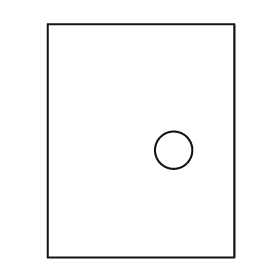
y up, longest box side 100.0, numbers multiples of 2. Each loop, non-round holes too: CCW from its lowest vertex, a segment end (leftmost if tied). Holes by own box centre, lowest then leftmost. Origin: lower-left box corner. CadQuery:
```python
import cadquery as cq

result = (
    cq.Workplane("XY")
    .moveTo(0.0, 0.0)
    .lineTo(80.0, 0.0)
    .lineTo(80.0, 100.0)
    .lineTo(0.0, 100.0)
    .close()
    .moveTo(54.0, 46.0)
    .circle(8.0)
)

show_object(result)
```